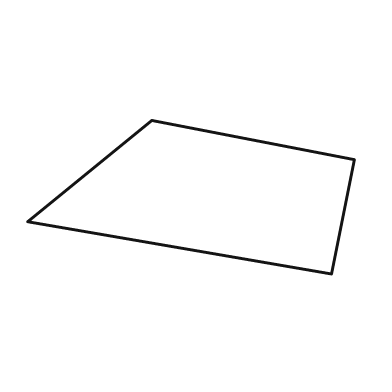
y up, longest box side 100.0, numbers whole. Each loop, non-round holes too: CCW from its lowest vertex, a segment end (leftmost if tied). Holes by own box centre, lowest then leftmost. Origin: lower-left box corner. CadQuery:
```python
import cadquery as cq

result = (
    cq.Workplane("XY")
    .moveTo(93.0, 0.0)
    .lineTo(100.0, 35.0)
    .lineTo(38.0, 47.0)
    .lineTo(0.0, 16.0)
    .close()
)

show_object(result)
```